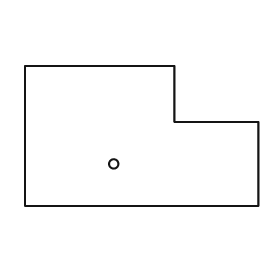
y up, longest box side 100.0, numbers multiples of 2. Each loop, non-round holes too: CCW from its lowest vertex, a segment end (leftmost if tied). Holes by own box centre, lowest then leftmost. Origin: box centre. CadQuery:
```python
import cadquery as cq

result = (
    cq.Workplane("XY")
    .moveTo(-50.0, -30.0)
    .lineTo(50.0, -30.0)
    .lineTo(50.0, 6.0)
    .lineTo(14.0, 6.0)
    .lineTo(14.0, 30.0)
    .lineTo(-50.0, 30.0)
    .close()
    .moveTo(-12.0, -12.0)
    .circle(2.0)
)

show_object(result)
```